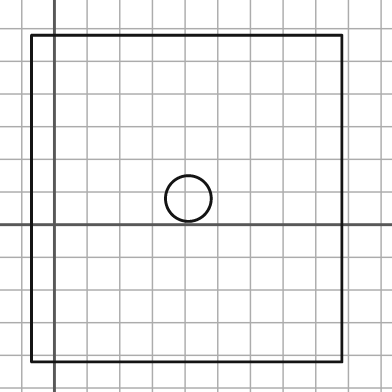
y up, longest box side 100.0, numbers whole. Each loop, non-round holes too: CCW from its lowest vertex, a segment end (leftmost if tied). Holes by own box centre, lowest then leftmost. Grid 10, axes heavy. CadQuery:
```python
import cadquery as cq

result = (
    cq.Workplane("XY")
    .moveTo(-7.0, -42.0)
    .lineTo(88.0, -42.0)
    .lineTo(88.0, 58.0)
    .lineTo(-7.0, 58.0)
    .close()
    .moveTo(41.0, 8.0)
    .circle(7.0)
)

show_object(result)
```